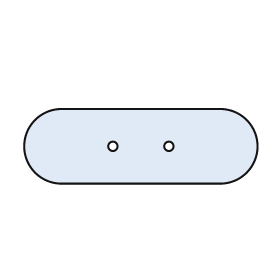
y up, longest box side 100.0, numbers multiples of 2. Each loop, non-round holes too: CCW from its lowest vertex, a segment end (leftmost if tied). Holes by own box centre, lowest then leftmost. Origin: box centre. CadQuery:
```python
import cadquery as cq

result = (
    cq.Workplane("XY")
    .moveTo(-34.0, -16.0)
    .lineTo(34.0, -16.0)
    .threePointArc((50.0, 0.0), (34.0, 16.0))
    .lineTo(-34.0, 16.0)
    .threePointArc((-50.0, 0.0), (-34.0, -16.0))
    .close()
    .moveTo(-12.0, 0.0)
    .circle(2.0)
    .moveTo(12.0, 0.0)
    .circle(2.0)
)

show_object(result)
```